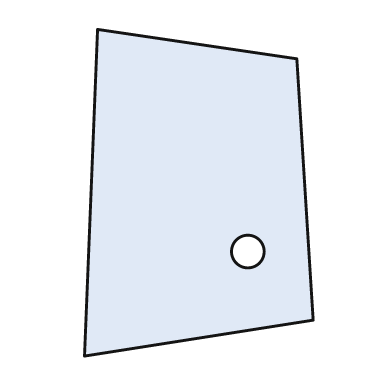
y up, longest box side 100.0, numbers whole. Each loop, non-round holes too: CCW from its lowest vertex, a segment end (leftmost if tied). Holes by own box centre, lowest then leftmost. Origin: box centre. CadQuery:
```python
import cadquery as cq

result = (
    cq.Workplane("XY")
    .moveTo(-35.0, -50.0)
    .lineTo(35.0, -39.0)
    .lineTo(30.0, 41.0)
    .lineTo(-31.0, 50.0)
    .close()
    .moveTo(15.0, -18.0)
    .circle(5.0)
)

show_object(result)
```